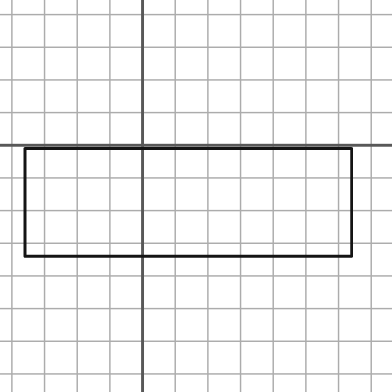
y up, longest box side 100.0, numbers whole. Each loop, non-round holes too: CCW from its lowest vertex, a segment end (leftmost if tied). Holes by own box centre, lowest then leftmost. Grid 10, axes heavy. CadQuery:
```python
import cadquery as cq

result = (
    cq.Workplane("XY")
    .moveTo(-36.0, -34.0)
    .lineTo(64.0, -34.0)
    .lineTo(64.0, -1.0)
    .lineTo(-36.0, -1.0)
    .close()
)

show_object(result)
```